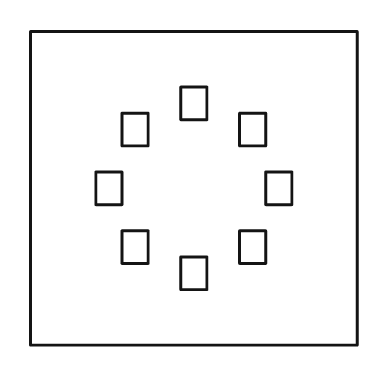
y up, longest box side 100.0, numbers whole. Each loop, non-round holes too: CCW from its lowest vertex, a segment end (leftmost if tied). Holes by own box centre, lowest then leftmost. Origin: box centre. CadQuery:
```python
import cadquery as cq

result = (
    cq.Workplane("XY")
    .moveTo(-50.0, -48.0)
    .lineTo(50.0, -48.0)
    .lineTo(50.0, 48.0)
    .lineTo(-50.0, 48.0)
    .close()
    .moveTo(-4.0, -31.0)
    .lineTo(4.0, -31.0)
    .lineTo(4.0, -21.0)
    .lineTo(-4.0, -21.0)
    .close()
    .moveTo(-22.0, -23.0)
    .lineTo(-14.0, -23.0)
    .lineTo(-14.0, -13.0)
    .lineTo(-22.0, -13.0)
    .close()
    .moveTo(14.0, -23.0)
    .lineTo(22.0, -23.0)
    .lineTo(22.0, -13.0)
    .lineTo(14.0, -13.0)
    .close()
    .moveTo(-30.0, -5.0)
    .lineTo(-22.0, -5.0)
    .lineTo(-22.0, 5.0)
    .lineTo(-30.0, 5.0)
    .close()
    .moveTo(22.0, -5.0)
    .lineTo(30.0, -5.0)
    .lineTo(30.0, 5.0)
    .lineTo(22.0, 5.0)
    .close()
    .moveTo(-22.0, 13.0)
    .lineTo(-14.0, 13.0)
    .lineTo(-14.0, 23.0)
    .lineTo(-22.0, 23.0)
    .close()
    .moveTo(14.0, 13.0)
    .lineTo(22.0, 13.0)
    .lineTo(22.0, 23.0)
    .lineTo(14.0, 23.0)
    .close()
    .moveTo(-4.0, 21.0)
    .lineTo(4.0, 21.0)
    .lineTo(4.0, 31.0)
    .lineTo(-4.0, 31.0)
    .close()
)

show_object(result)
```